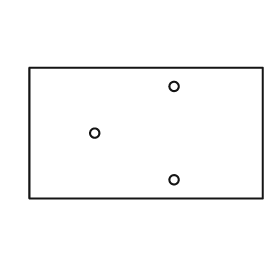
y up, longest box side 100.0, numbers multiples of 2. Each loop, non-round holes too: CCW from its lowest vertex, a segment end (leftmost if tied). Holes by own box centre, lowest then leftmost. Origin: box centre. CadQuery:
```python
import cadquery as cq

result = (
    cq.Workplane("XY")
    .moveTo(-50.0, -28.0)
    .lineTo(50.0, -28.0)
    .lineTo(50.0, 28.0)
    .lineTo(-50.0, 28.0)
    .close()
    .moveTo(12.0, -20.0)
    .circle(2.0)
    .moveTo(-22.0, 0.0)
    .circle(2.0)
    .moveTo(12.0, 20.0)
    .circle(2.0)
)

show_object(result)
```